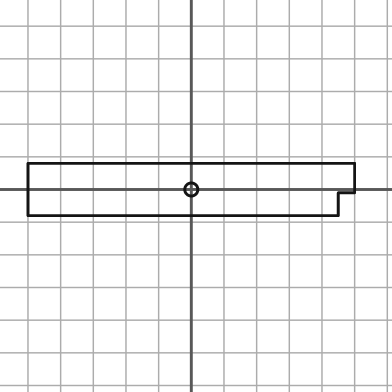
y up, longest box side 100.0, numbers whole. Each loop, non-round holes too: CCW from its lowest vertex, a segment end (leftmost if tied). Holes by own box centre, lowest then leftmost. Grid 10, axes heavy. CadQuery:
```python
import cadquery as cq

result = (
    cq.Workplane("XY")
    .moveTo(-50.0, -8.0)
    .lineTo(45.0, -8.0)
    .lineTo(45.0, -1.0)
    .lineTo(50.0, -1.0)
    .lineTo(50.0, 8.0)
    .lineTo(-50.0, 8.0)
    .close()
    .moveTo(0.0, 0.0)
    .circle(2.0)
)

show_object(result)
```